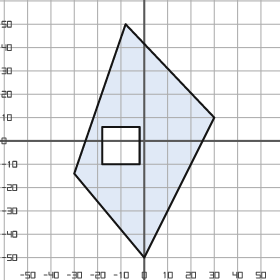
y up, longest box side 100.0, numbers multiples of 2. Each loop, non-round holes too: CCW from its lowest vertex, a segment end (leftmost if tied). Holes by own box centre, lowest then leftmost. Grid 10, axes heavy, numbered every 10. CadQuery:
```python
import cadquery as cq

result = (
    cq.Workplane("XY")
    .moveTo(0.0, -50.0)
    .lineTo(30.0, 10.0)
    .lineTo(-8.0, 50.0)
    .lineTo(-30.0, -14.0)
    .close()
    .moveTo(-18.0, -10.0)
    .lineTo(-2.0, -10.0)
    .lineTo(-2.0, 6.0)
    .lineTo(-18.0, 6.0)
    .close()
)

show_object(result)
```